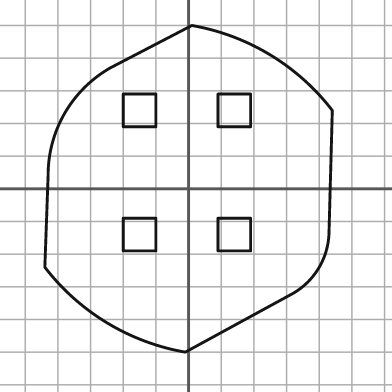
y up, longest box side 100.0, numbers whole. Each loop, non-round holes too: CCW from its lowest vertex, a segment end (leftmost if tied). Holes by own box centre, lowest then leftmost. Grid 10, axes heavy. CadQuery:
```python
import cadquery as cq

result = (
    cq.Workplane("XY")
    .moveTo(-1.0, -50.0)
    .lineTo(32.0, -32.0)
    .threePointArc((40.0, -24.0), (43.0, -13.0))
    .lineTo(44.0, 24.0)
    .threePointArc((25.0, 41.0), (1.0, 50.0))
    .lineTo(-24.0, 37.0)
    .threePointArc((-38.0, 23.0), (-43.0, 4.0))
    .lineTo(-44.0, -24.0)
    .threePointArc((-25.0, -41.0), (-1.0, -50.0))
    .close()
    .moveTo(-20.0, -19.0)
    .lineTo(-10.0, -19.0)
    .lineTo(-10.0, -9.0)
    .lineTo(-20.0, -9.0)
    .close()
    .moveTo(9.0, -19.0)
    .lineTo(19.0, -19.0)
    .lineTo(19.0, -9.0)
    .lineTo(9.0, -9.0)
    .close()
    .moveTo(-20.0, 19.0)
    .lineTo(-10.0, 19.0)
    .lineTo(-10.0, 29.0)
    .lineTo(-20.0, 29.0)
    .close()
    .moveTo(9.0, 19.0)
    .lineTo(19.0, 19.0)
    .lineTo(19.0, 29.0)
    .lineTo(9.0, 29.0)
    .close()
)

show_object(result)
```